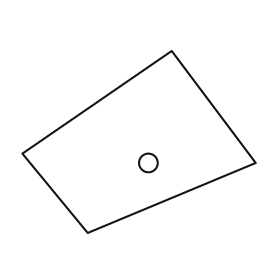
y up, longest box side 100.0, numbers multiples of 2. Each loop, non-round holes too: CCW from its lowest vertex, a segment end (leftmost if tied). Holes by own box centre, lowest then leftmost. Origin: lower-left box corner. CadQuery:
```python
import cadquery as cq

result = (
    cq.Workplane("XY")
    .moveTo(28.0, 0.0)
    .lineTo(100.0, 30.0)
    .lineTo(64.0, 78.0)
    .lineTo(0.0, 34.0)
    .close()
    .moveTo(54.0, 30.0)
    .circle(4.0)
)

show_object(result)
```